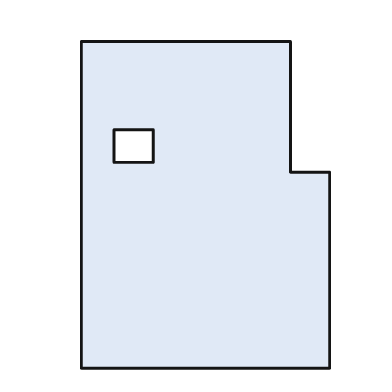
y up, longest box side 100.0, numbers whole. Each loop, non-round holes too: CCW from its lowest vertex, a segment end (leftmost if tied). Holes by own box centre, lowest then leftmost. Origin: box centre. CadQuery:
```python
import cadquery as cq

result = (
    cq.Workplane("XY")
    .moveTo(-38.0, -50.0)
    .lineTo(38.0, -50.0)
    .lineTo(38.0, 10.0)
    .lineTo(26.0, 10.0)
    .lineTo(26.0, 50.0)
    .lineTo(-38.0, 50.0)
    .close()
    .moveTo(-28.0, 13.0)
    .lineTo(-16.0, 13.0)
    .lineTo(-16.0, 23.0)
    .lineTo(-28.0, 23.0)
    .close()
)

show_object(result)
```